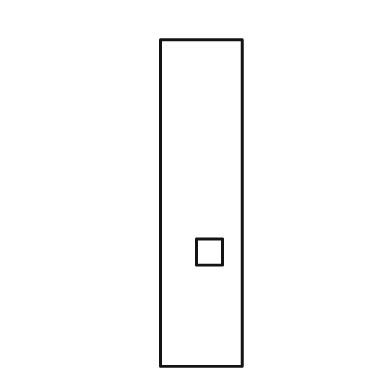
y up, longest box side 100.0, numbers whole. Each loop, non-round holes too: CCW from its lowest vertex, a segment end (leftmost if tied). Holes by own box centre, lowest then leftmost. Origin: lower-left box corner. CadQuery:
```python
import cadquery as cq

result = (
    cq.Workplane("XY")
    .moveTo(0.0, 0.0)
    .lineTo(25.0, 0.0)
    .lineTo(25.0, 100.0)
    .lineTo(0.0, 100.0)
    .close()
    .moveTo(11.0, 31.0)
    .lineTo(19.0, 31.0)
    .lineTo(19.0, 39.0)
    .lineTo(11.0, 39.0)
    .close()
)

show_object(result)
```